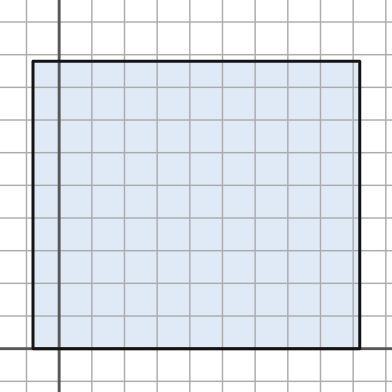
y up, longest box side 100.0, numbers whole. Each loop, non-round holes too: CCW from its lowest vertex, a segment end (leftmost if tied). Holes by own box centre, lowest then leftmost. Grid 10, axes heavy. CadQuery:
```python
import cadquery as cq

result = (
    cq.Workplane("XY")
    .moveTo(-8.0, 0.0)
    .lineTo(92.0, 0.0)
    .lineTo(92.0, 88.0)
    .lineTo(-8.0, 88.0)
    .close()
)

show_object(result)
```